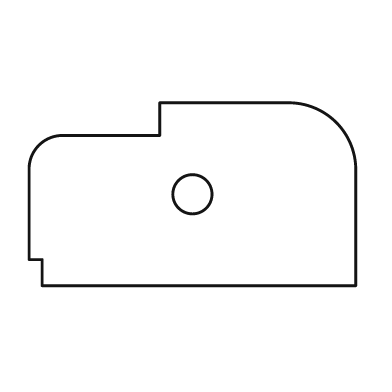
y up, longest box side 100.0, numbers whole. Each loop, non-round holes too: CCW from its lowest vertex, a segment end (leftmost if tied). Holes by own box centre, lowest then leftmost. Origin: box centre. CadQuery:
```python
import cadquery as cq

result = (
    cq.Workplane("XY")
    .moveTo(-46.0, -28.0)
    .lineTo(50.0, -28.0)
    .lineTo(50.0, 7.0)
    .threePointArc((44.0, 22.0), (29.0, 28.0))
    .lineTo(-10.0, 28.0)
    .lineTo(-10.0, 18.0)
    .lineTo(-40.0, 18.0)
    .threePointArc((-47.0, 15.0), (-50.0, 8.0))
    .lineTo(-50.0, -20.0)
    .lineTo(-46.0, -20.0)
    .close()
    .moveTo(0.0, 0.0)
    .circle(6.0)
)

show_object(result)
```